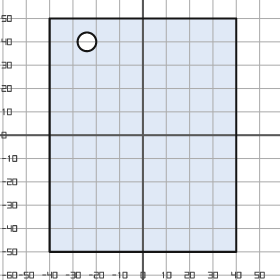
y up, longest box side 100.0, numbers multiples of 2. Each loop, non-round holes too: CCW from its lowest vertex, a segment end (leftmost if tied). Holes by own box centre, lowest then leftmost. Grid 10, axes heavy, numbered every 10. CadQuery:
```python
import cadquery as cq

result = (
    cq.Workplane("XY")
    .moveTo(-40.0, -50.0)
    .lineTo(40.0, -50.0)
    .lineTo(40.0, 50.0)
    .lineTo(-40.0, 50.0)
    .close()
    .moveTo(-24.0, 40.0)
    .circle(4.0)
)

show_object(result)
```